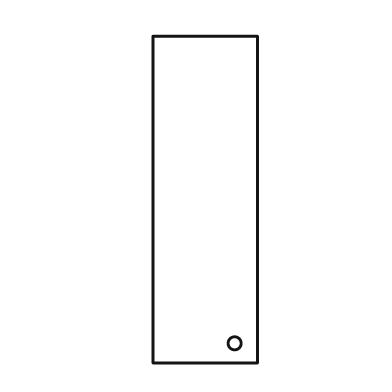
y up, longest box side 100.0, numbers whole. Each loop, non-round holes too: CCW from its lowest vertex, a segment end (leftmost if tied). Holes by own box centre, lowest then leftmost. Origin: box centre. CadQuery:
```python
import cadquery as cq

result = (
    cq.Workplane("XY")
    .moveTo(-16.0, -50.0)
    .lineTo(16.0, -50.0)
    .lineTo(16.0, 50.0)
    .lineTo(-16.0, 50.0)
    .close()
    .moveTo(9.0, -44.0)
    .circle(2.0)
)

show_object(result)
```